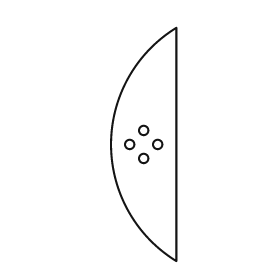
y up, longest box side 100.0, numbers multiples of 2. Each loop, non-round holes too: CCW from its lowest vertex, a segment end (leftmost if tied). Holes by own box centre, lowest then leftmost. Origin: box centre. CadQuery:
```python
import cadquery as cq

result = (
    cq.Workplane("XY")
    .moveTo(14.0, -50.0)
    .lineTo(14.0, 50.0)
    .threePointArc((-14.0, 0.0), (14.0, -50.0))
    .close()
    .moveTo(0.0, -6.0)
    .circle(2.0)
    .moveTo(-6.0, 0.0)
    .circle(2.0)
    .moveTo(6.0, 0.0)
    .circle(2.0)
    .moveTo(0.0, 6.0)
    .circle(2.0)
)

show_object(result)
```